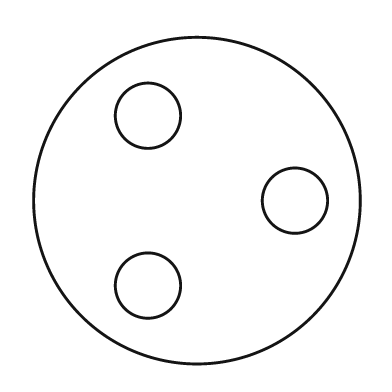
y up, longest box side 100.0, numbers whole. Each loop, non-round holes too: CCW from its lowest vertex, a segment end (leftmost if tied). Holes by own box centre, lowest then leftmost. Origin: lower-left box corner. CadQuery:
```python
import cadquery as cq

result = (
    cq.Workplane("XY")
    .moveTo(50.0, 50.0)
    .circle(50.0)
    .moveTo(35.0, 24.0)
    .circle(10.0)
    .moveTo(80.0, 50.0)
    .circle(10.0)
    .moveTo(35.0, 76.0)
    .circle(10.0)
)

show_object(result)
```